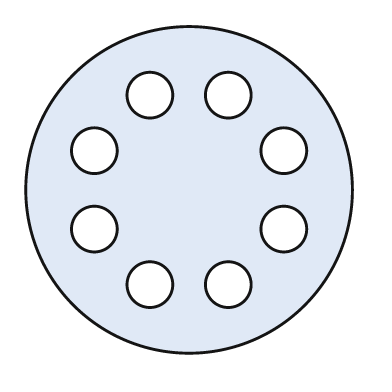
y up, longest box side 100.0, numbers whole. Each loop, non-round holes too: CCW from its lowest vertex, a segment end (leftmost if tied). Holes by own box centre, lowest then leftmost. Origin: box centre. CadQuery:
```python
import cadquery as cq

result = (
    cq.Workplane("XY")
    .moveTo(0.0, 0.0)
    .circle(50.0)
    .moveTo(-12.0, -29.0)
    .circle(7.0)
    .moveTo(12.0, -29.0)
    .circle(7.0)
    .moveTo(-29.0, -12.0)
    .circle(7.0)
    .moveTo(29.0, -12.0)
    .circle(7.0)
    .moveTo(-29.0, 12.0)
    .circle(7.0)
    .moveTo(29.0, 12.0)
    .circle(7.0)
    .moveTo(-12.0, 29.0)
    .circle(7.0)
    .moveTo(12.0, 29.0)
    .circle(7.0)
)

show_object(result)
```